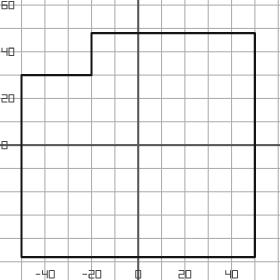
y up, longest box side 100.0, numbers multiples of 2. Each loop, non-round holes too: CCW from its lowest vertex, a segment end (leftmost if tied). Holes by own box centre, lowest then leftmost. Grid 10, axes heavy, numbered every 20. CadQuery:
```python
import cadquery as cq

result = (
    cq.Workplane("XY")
    .moveTo(-50.0, -48.0)
    .lineTo(50.0, -48.0)
    .lineTo(50.0, 48.0)
    .lineTo(-20.0, 48.0)
    .lineTo(-20.0, 30.0)
    .lineTo(-50.0, 30.0)
    .close()
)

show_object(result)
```